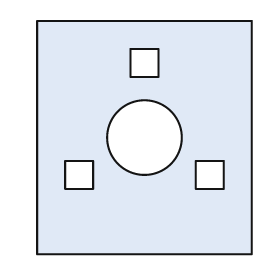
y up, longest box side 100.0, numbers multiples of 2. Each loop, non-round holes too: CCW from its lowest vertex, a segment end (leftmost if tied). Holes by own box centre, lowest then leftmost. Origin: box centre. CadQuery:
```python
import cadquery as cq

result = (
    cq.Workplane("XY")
    .moveTo(-46.0, -50.0)
    .lineTo(46.0, -50.0)
    .lineTo(46.0, 50.0)
    .lineTo(-46.0, 50.0)
    .close()
    .moveTo(-34.0, -22.0)
    .lineTo(-22.0, -22.0)
    .lineTo(-22.0, -10.0)
    .lineTo(-34.0, -10.0)
    .close()
    .moveTo(22.0, -22.0)
    .lineTo(34.0, -22.0)
    .lineTo(34.0, -10.0)
    .lineTo(22.0, -10.0)
    .close()
    .moveTo(0.0, 0.0)
    .circle(16.0)
    .moveTo(-6.0, 26.0)
    .lineTo(6.0, 26.0)
    .lineTo(6.0, 38.0)
    .lineTo(-6.0, 38.0)
    .close()
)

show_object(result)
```